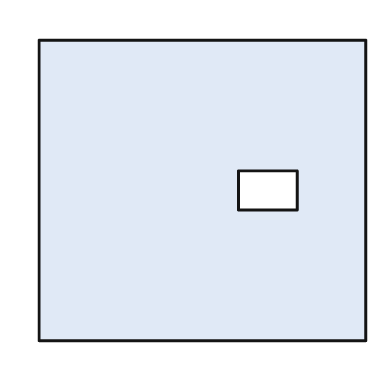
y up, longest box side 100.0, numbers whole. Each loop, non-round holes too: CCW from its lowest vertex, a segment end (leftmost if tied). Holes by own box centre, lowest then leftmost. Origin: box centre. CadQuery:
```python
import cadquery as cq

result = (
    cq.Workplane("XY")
    .moveTo(-50.0, -46.0)
    .lineTo(50.0, -46.0)
    .lineTo(50.0, 46.0)
    .lineTo(-50.0, 46.0)
    .close()
    .moveTo(11.0, -6.0)
    .lineTo(29.0, -6.0)
    .lineTo(29.0, 6.0)
    .lineTo(11.0, 6.0)
    .close()
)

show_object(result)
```